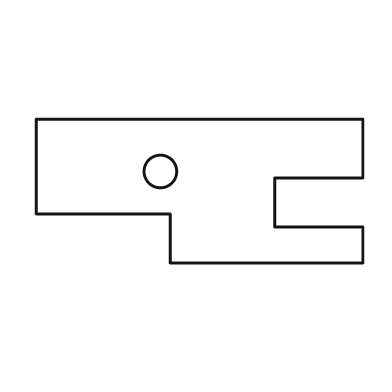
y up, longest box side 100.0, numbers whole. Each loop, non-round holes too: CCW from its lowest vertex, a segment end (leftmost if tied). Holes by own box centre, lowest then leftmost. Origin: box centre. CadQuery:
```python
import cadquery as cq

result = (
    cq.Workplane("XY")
    .moveTo(-9.0, -22.0)
    .lineTo(50.0, -22.0)
    .lineTo(50.0, -11.0)
    .lineTo(23.0, -11.0)
    .lineTo(23.0, 4.0)
    .lineTo(50.0, 4.0)
    .lineTo(50.0, 22.0)
    .lineTo(-50.0, 22.0)
    .lineTo(-50.0, -7.0)
    .lineTo(-9.0, -7.0)
    .close()
    .moveTo(-12.0, 6.0)
    .circle(5.0)
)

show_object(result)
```